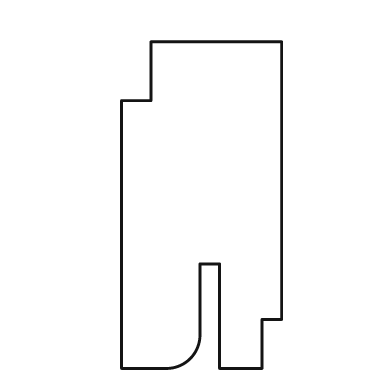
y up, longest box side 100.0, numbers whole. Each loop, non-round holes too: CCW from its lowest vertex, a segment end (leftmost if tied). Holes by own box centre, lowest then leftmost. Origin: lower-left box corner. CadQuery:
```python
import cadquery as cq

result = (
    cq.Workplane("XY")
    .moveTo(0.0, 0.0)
    .lineTo(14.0, 0.0)
    .threePointArc((21.0, 3.0), (24.0, 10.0))
    .lineTo(24.0, 32.0)
    .lineTo(30.0, 32.0)
    .lineTo(30.0, 0.0)
    .lineTo(43.0, 0.0)
    .lineTo(43.0, 15.0)
    .lineTo(49.0, 15.0)
    .lineTo(49.0, 100.0)
    .lineTo(9.0, 100.0)
    .lineTo(9.0, 82.0)
    .lineTo(0.0, 82.0)
    .close()
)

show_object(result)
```